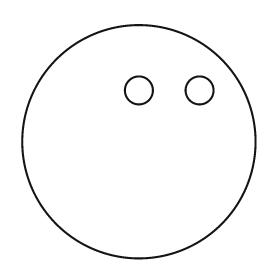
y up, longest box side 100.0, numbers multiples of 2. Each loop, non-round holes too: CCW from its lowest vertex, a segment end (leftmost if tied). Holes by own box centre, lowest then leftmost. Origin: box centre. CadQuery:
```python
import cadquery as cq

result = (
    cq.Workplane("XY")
    .moveTo(0.0, 0.0)
    .circle(50.0)
    .moveTo(0.0, 22.0)
    .circle(6.0)
    .moveTo(26.0, 22.0)
    .circle(6.0)
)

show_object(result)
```